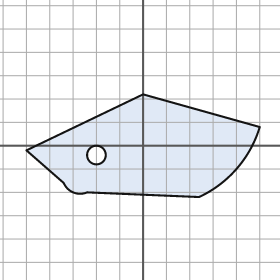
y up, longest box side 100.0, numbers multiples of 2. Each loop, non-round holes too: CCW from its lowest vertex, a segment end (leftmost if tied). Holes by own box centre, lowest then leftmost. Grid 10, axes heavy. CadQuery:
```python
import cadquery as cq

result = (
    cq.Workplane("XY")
    .moveTo(24.0, -22.0)
    .threePointArc((40.0, -10.0), (50.0, 8.0))
    .lineTo(0.0, 22.0)
    .lineTo(-50.0, -2.0)
    .lineTo(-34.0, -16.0)
    .threePointArc((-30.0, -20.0), (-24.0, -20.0))
    .close()
    .moveTo(-20.0, -4.0)
    .circle(4.0)
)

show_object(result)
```